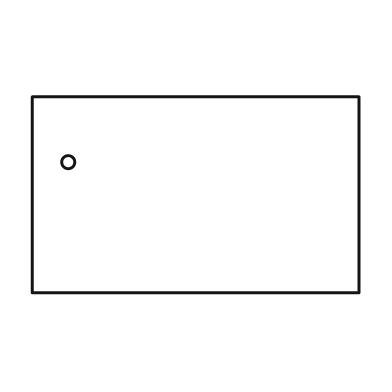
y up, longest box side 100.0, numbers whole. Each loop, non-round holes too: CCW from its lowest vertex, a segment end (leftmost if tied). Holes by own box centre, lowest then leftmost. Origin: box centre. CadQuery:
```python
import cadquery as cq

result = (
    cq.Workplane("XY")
    .moveTo(-50.0, -30.0)
    .lineTo(50.0, -30.0)
    .lineTo(50.0, 30.0)
    .lineTo(-50.0, 30.0)
    .close()
    .moveTo(-39.0, 10.0)
    .circle(2.0)
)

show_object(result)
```